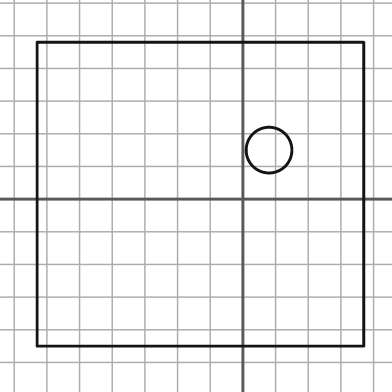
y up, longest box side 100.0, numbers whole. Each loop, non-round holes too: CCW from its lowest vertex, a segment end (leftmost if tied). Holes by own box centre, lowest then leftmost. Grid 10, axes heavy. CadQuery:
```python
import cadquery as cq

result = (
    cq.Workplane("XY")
    .moveTo(-63.0, -45.0)
    .lineTo(37.0, -45.0)
    .lineTo(37.0, 48.0)
    .lineTo(-63.0, 48.0)
    .close()
    .moveTo(8.0, 15.0)
    .circle(7.0)
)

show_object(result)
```